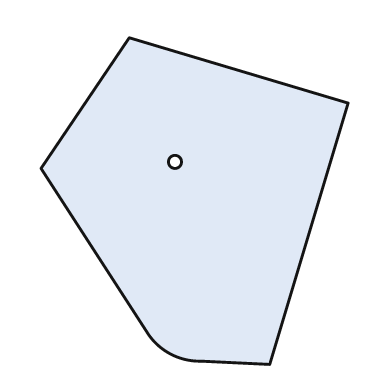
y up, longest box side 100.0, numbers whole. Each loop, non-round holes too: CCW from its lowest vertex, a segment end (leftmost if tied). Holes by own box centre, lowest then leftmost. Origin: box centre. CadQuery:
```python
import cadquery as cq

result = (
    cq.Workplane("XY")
    .moveTo(23.0, -50.0)
    .lineTo(47.0, 30.0)
    .lineTo(-20.0, 50.0)
    .lineTo(-47.0, 10.0)
    .lineTo(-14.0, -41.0)
    .threePointArc((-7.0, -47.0), (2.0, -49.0))
    .close()
    .moveTo(-6.0, 12.0)
    .circle(2.0)
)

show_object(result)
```